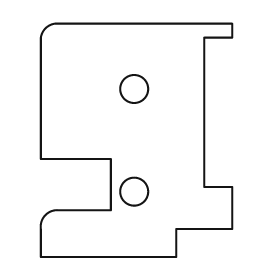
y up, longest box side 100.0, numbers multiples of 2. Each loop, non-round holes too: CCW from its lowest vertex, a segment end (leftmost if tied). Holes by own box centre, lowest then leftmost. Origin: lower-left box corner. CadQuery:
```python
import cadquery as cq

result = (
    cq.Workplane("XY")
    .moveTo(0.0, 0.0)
    .lineTo(58.0, 0.0)
    .lineTo(58.0, 12.0)
    .lineTo(82.0, 12.0)
    .lineTo(82.0, 30.0)
    .lineTo(70.0, 30.0)
    .lineTo(70.0, 94.0)
    .lineTo(82.0, 94.0)
    .lineTo(82.0, 100.0)
    .lineTo(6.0, 100.0)
    .threePointArc((2.0, 98.0), (0.0, 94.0))
    .lineTo(0.0, 42.0)
    .lineTo(30.0, 42.0)
    .lineTo(30.0, 20.0)
    .lineTo(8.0, 20.0)
    .threePointArc((2.0, 18.0), (0.0, 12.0))
    .close()
    .moveTo(40.0, 28.0)
    .circle(6.0)
    .moveTo(40.0, 72.0)
    .circle(6.0)
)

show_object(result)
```